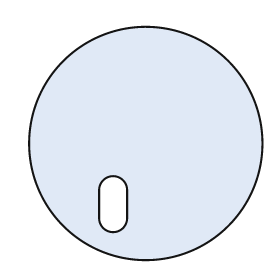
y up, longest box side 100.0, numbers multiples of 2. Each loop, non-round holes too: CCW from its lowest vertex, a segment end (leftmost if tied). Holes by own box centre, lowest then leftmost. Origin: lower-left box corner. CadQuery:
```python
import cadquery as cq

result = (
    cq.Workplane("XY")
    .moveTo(50.0, 50.0)
    .circle(50.0)
    .moveTo(30.0, 18.0)
    .threePointArc((36.0, 12.0), (42.0, 18.0))
    .lineTo(42.0, 30.0)
    .threePointArc((36.0, 36.0), (30.0, 30.0))
    .close()
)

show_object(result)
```